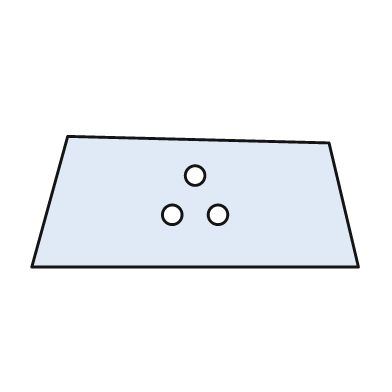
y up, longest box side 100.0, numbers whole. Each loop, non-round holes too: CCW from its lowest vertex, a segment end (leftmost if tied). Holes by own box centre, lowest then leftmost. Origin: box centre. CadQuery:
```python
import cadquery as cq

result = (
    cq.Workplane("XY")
    .moveTo(-50.0, -20.0)
    .lineTo(50.0, -20.0)
    .lineTo(41.0, 18.0)
    .lineTo(-39.0, 20.0)
    .close()
    .moveTo(-7.0, -4.0)
    .circle(3.0)
    .moveTo(7.0, -4.0)
    .circle(3.0)
    .moveTo(0.0, 8.0)
    .circle(3.0)
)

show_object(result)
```